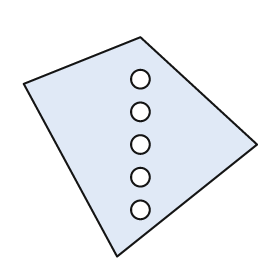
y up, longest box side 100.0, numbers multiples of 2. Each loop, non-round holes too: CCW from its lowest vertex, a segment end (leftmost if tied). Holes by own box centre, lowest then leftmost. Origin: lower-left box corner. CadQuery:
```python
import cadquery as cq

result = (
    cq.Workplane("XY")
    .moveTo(40.0, 0.0)
    .lineTo(100.0, 48.0)
    .lineTo(50.0, 94.0)
    .lineTo(0.0, 74.0)
    .close()
    .moveTo(50.0, 20.0)
    .circle(4.0)
    .moveTo(50.0, 34.0)
    .circle(4.0)
    .moveTo(50.0, 48.0)
    .circle(4.0)
    .moveTo(50.0, 62.0)
    .circle(4.0)
    .moveTo(50.0, 76.0)
    .circle(4.0)
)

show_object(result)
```